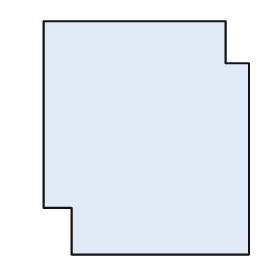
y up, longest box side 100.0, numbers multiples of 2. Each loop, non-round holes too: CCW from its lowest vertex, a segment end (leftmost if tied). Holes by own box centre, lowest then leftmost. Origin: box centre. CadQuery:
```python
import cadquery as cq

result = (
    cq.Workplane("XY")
    .moveTo(-32.0, -50.0)
    .lineTo(44.0, -50.0)
    .lineTo(44.0, 32.0)
    .lineTo(34.0, 32.0)
    .lineTo(34.0, 50.0)
    .lineTo(-44.0, 50.0)
    .lineTo(-44.0, -30.0)
    .lineTo(-32.0, -30.0)
    .close()
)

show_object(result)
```